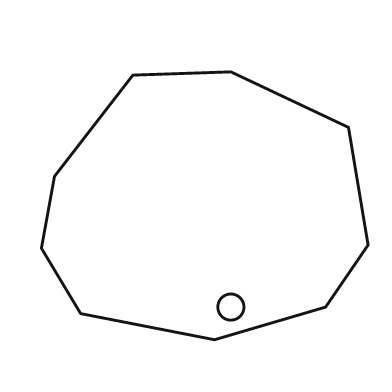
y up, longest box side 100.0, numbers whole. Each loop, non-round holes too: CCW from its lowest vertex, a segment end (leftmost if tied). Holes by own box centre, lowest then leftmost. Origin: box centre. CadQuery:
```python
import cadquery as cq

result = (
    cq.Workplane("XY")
    .moveTo(3.0, -41.0)
    .lineTo(37.0, -31.0)
    .lineTo(50.0, -12.0)
    .lineTo(44.0, 24.0)
    .lineTo(8.0, 41.0)
    .lineTo(-22.0, 40.0)
    .lineTo(-46.0, 9.0)
    .lineTo(-50.0, -13.0)
    .lineTo(-38.0, -33.0)
    .close()
    .moveTo(8.0, -31.0)
    .circle(4.0)
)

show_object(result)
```